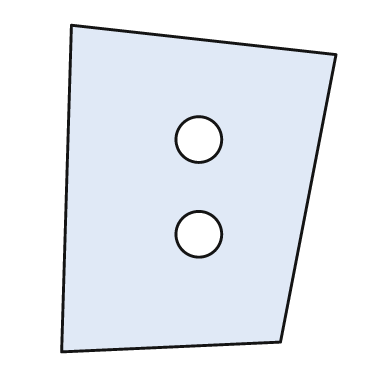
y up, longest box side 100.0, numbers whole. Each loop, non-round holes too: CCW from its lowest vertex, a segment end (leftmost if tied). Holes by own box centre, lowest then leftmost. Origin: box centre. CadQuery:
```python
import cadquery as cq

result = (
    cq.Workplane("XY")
    .moveTo(-42.0, -50.0)
    .lineTo(25.0, -47.0)
    .lineTo(42.0, 41.0)
    .lineTo(-39.0, 50.0)
    .close()
    .moveTo(0.0, -14.0)
    .circle(7.0)
    .moveTo(0.0, 15.0)
    .circle(7.0)
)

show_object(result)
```